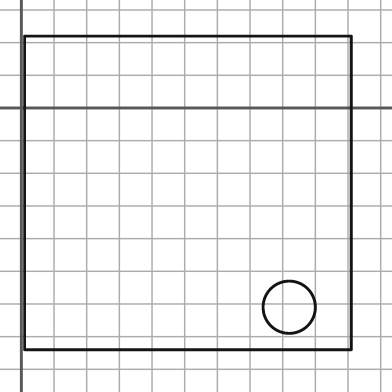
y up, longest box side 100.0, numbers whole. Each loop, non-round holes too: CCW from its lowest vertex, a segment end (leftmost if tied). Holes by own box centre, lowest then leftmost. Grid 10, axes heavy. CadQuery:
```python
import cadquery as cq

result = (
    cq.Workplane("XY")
    .moveTo(1.0, -74.0)
    .lineTo(101.0, -74.0)
    .lineTo(101.0, 22.0)
    .lineTo(1.0, 22.0)
    .close()
    .moveTo(82.0, -61.0)
    .circle(8.0)
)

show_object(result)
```